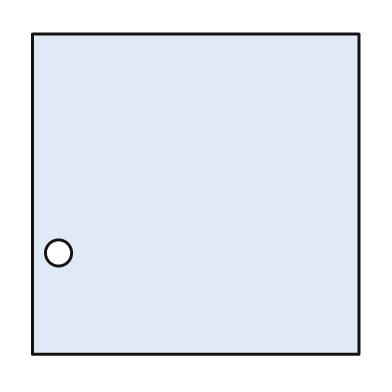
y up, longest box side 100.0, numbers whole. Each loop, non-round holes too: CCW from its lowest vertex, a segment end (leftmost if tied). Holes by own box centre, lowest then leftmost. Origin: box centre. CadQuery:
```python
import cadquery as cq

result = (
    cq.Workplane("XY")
    .moveTo(-50.0, -49.0)
    .lineTo(50.0, -49.0)
    .lineTo(50.0, 49.0)
    .lineTo(-50.0, 49.0)
    .close()
    .moveTo(-42.0, -18.0)
    .circle(4.0)
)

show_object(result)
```